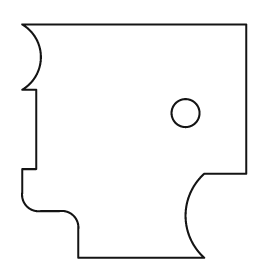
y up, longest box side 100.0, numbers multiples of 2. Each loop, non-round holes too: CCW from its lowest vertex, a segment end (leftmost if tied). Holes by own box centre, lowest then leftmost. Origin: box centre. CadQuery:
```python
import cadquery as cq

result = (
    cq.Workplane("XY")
    .moveTo(-24.0, -50.0)
    .lineTo(30.0, -50.0)
    .threePointArc((22.0, -32.0), (30.0, -14.0))
    .lineTo(48.0, -14.0)
    .lineTo(48.0, 50.0)
    .lineTo(-48.0, 50.0)
    .threePointArc((-40.0, 36.0), (-48.0, 22.0))
    .lineTo(-42.0, 22.0)
    .lineTo(-42.0, -12.0)
    .lineTo(-48.0, -12.0)
    .lineTo(-48.0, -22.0)
    .threePointArc((-46.0, -28.0), (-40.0, -30.0))
    .lineTo(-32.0, -30.0)
    .threePointArc((-26.0, -32.0), (-24.0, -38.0))
    .close()
    .moveTo(22.0, 12.0)
    .circle(6.0)
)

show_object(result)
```